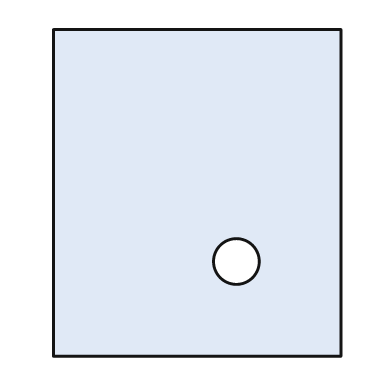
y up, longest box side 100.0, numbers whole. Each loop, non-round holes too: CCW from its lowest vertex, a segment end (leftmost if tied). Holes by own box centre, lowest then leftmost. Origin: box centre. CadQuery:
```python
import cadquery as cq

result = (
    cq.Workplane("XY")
    .moveTo(-44.0, -50.0)
    .lineTo(44.0, -50.0)
    .lineTo(44.0, 50.0)
    .lineTo(-44.0, 50.0)
    .close()
    .moveTo(12.0, -21.0)
    .circle(7.0)
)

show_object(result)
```